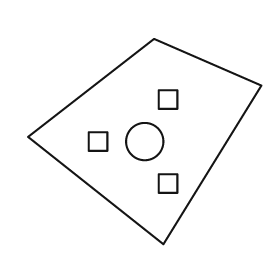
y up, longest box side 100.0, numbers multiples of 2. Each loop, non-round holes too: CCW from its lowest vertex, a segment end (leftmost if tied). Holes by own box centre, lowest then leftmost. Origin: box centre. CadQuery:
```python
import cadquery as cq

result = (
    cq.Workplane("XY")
    .moveTo(8.0, -44.0)
    .lineTo(50.0, 24.0)
    .lineTo(4.0, 44.0)
    .lineTo(-50.0, 2.0)
    .close()
    .moveTo(6.0, -22.0)
    .lineTo(14.0, -22.0)
    .lineTo(14.0, -14.0)
    .lineTo(6.0, -14.0)
    .close()
    .moveTo(-24.0, -4.0)
    .lineTo(-16.0, -4.0)
    .lineTo(-16.0, 4.0)
    .lineTo(-24.0, 4.0)
    .close()
    .moveTo(0.0, 0.0)
    .circle(8.0)
    .moveTo(6.0, 14.0)
    .lineTo(14.0, 14.0)
    .lineTo(14.0, 22.0)
    .lineTo(6.0, 22.0)
    .close()
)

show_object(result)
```